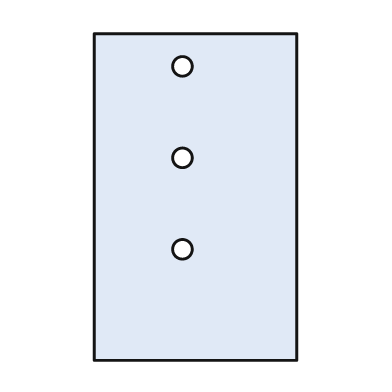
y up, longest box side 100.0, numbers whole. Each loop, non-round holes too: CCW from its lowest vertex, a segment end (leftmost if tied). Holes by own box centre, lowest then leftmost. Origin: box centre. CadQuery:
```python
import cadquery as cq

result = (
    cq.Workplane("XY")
    .moveTo(-31.0, -50.0)
    .lineTo(31.0, -50.0)
    .lineTo(31.0, 50.0)
    .lineTo(-31.0, 50.0)
    .close()
    .moveTo(-4.0, -16.0)
    .circle(3.0)
    .moveTo(-4.0, 12.0)
    .circle(3.0)
    .moveTo(-4.0, 40.0)
    .circle(3.0)
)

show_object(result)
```